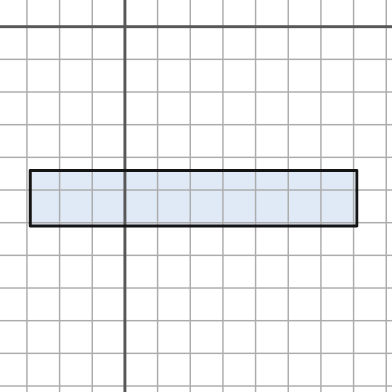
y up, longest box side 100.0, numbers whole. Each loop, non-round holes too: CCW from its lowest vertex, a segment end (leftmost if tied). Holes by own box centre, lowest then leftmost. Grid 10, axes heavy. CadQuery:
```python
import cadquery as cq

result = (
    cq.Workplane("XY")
    .moveTo(-29.0, -61.0)
    .lineTo(71.0, -61.0)
    .lineTo(71.0, -44.0)
    .lineTo(-29.0, -44.0)
    .close()
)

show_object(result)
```